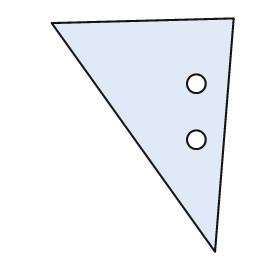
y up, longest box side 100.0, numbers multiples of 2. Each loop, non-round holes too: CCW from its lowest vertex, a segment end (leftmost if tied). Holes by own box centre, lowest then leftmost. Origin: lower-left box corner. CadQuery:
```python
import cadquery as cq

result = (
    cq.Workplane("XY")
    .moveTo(70.0, 0.0)
    .lineTo(78.0, 100.0)
    .lineTo(0.0, 98.0)
    .close()
    .moveTo(62.0, 48.0)
    .circle(4.0)
    .moveTo(62.0, 72.0)
    .circle(4.0)
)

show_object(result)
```